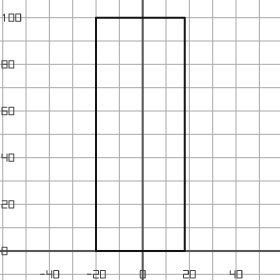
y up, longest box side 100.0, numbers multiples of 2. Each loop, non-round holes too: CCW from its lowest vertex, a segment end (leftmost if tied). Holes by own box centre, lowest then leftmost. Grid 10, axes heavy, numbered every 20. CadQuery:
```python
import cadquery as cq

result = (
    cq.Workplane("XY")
    .moveTo(-20.0, 0.0)
    .lineTo(18.0, 0.0)
    .lineTo(18.0, 100.0)
    .lineTo(-20.0, 100.0)
    .close()
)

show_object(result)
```